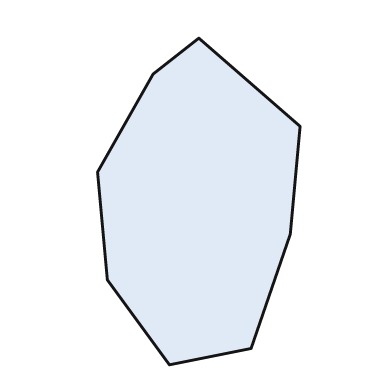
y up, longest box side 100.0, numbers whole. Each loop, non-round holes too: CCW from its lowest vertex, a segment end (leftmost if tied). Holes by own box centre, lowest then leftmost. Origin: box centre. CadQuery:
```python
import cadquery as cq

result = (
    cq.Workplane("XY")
    .moveTo(-9.0, -50.0)
    .lineTo(16.0, -45.0)
    .lineTo(28.0, -10.0)
    .lineTo(31.0, 23.0)
    .lineTo(0.0, 50.0)
    .lineTo(-14.0, 39.0)
    .lineTo(-31.0, 9.0)
    .lineTo(-28.0, -24.0)
    .close()
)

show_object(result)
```